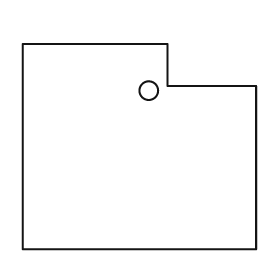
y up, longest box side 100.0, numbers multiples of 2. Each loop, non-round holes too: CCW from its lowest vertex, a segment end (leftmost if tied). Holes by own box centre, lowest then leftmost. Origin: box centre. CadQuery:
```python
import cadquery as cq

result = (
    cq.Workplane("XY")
    .moveTo(-50.0, -44.0)
    .lineTo(50.0, -44.0)
    .lineTo(50.0, 26.0)
    .lineTo(12.0, 26.0)
    .lineTo(12.0, 44.0)
    .lineTo(-50.0, 44.0)
    .close()
    .moveTo(4.0, 24.0)
    .circle(4.0)
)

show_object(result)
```